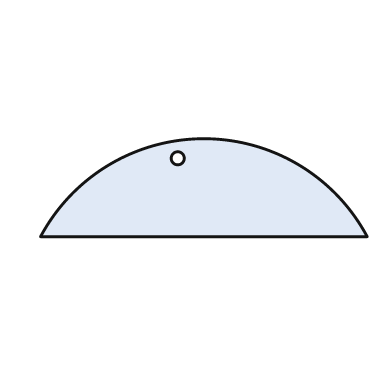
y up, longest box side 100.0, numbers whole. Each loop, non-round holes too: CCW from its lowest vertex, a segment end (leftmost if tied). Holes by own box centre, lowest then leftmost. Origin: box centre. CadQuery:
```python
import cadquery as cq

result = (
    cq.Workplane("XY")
    .moveTo(-50.0, -15.0)
    .lineTo(50.0, -15.0)
    .threePointArc((0.0, 15.0), (-50.0, -15.0))
    .close()
    .moveTo(-8.0, 9.0)
    .circle(2.0)
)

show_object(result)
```